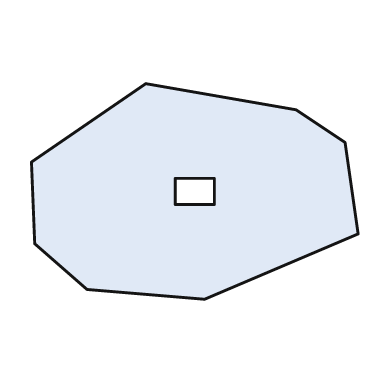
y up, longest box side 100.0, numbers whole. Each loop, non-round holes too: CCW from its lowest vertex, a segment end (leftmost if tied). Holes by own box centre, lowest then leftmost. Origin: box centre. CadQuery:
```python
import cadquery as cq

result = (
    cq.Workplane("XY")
    .moveTo(3.0, -33.0)
    .lineTo(50.0, -13.0)
    .lineTo(46.0, 15.0)
    .lineTo(31.0, 25.0)
    .lineTo(-15.0, 33.0)
    .lineTo(-50.0, 9.0)
    .lineTo(-49.0, -16.0)
    .lineTo(-33.0, -30.0)
    .close()
    .moveTo(-6.0, -4.0)
    .lineTo(6.0, -4.0)
    .lineTo(6.0, 4.0)
    .lineTo(-6.0, 4.0)
    .close()
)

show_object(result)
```